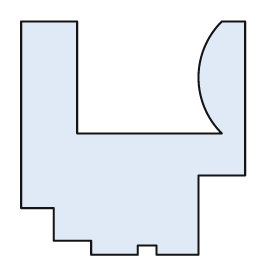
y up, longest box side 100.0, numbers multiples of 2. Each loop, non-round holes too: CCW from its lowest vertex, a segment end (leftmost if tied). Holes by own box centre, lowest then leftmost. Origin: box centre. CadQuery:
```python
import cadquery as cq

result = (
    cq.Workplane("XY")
    .moveTo(-18.0, -50.0)
    .lineTo(2.0, -50.0)
    .lineTo(2.0, -46.0)
    .lineTo(10.0, -46.0)
    .lineTo(10.0, -50.0)
    .lineTo(28.0, -50.0)
    .lineTo(28.0, -16.0)
    .lineTo(48.0, -16.0)
    .lineTo(48.0, 50.0)
    .lineTo(38.0, 50.0)
    .threePointArc((28.0, 26.0), (38.0, 2.0))
    .lineTo(-24.0, 2.0)
    .lineTo(-24.0, 50.0)
    .lineTo(-48.0, 50.0)
    .lineTo(-48.0, -30.0)
    .lineTo(-34.0, -30.0)
    .lineTo(-34.0, -44.0)
    .lineTo(-18.0, -44.0)
    .close()
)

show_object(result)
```